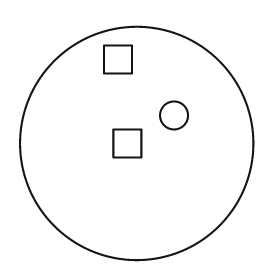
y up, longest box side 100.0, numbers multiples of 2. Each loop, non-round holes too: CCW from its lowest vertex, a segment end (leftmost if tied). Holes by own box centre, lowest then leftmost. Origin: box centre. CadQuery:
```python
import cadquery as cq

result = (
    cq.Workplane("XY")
    .moveTo(0.0, 0.0)
    .circle(50.0)
    .moveTo(-10.0, -6.0)
    .lineTo(2.0, -6.0)
    .lineTo(2.0, 6.0)
    .lineTo(-10.0, 6.0)
    .close()
    .moveTo(16.0, 12.0)
    .circle(6.0)
    .moveTo(-14.0, 30.0)
    .lineTo(-2.0, 30.0)
    .lineTo(-2.0, 42.0)
    .lineTo(-14.0, 42.0)
    .close()
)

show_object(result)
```